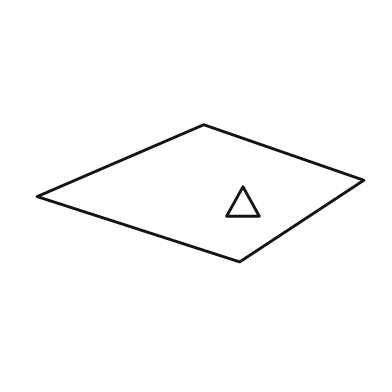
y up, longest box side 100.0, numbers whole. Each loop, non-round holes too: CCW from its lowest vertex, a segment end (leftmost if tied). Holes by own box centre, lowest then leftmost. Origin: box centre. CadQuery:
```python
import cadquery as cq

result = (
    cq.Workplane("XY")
    .moveTo(12.0, -21.0)
    .lineTo(50.0, 4.0)
    .lineTo(1.0, 21.0)
    .lineTo(-50.0, -1.0)
    .close()
    .moveTo(8.0, -7.0)
    .lineTo(18.0, -7.0)
    .lineTo(13.0, 2.0)
    .close()
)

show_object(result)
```